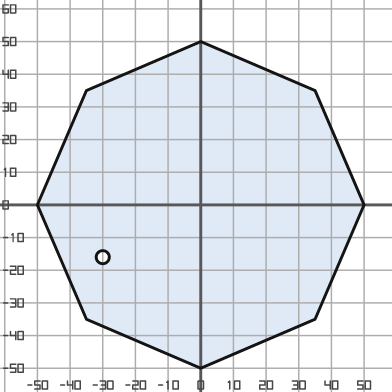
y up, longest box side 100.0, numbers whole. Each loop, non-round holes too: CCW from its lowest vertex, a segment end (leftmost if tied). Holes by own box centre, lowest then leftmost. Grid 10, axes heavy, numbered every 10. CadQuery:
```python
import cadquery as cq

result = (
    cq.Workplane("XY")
    .moveTo(0.0, -50.0)
    .lineTo(35.0, -35.0)
    .lineTo(50.0, 0.0)
    .lineTo(35.0, 35.0)
    .lineTo(0.0, 50.0)
    .lineTo(-35.0, 35.0)
    .lineTo(-50.0, 0.0)
    .lineTo(-35.0, -35.0)
    .close()
    .moveTo(-30.0, -16.0)
    .circle(2.0)
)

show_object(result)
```